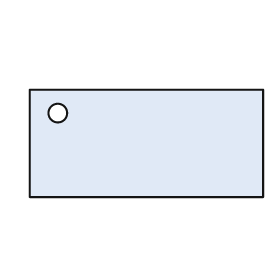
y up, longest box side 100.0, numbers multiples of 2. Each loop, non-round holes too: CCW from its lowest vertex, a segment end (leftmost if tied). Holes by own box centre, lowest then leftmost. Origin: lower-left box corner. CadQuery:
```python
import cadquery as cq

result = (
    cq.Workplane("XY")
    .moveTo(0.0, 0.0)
    .lineTo(100.0, 0.0)
    .lineTo(100.0, 46.0)
    .lineTo(0.0, 46.0)
    .close()
    .moveTo(12.0, 36.0)
    .circle(4.0)
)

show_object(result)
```